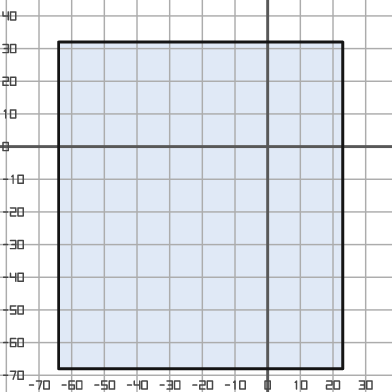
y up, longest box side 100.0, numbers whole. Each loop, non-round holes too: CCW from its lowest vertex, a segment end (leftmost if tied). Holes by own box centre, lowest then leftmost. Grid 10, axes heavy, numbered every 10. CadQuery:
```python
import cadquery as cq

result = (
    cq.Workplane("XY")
    .moveTo(-64.0, -68.0)
    .lineTo(23.0, -68.0)
    .lineTo(23.0, 32.0)
    .lineTo(-64.0, 32.0)
    .close()
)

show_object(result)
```